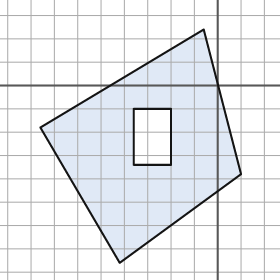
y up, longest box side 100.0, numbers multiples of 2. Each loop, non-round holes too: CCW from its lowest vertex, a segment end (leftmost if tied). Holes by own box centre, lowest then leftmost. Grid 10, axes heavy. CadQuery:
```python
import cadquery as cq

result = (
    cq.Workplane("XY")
    .moveTo(-42.0, -76.0)
    .lineTo(10.0, -38.0)
    .lineTo(-6.0, 24.0)
    .lineTo(-76.0, -18.0)
    .close()
    .moveTo(-36.0, -34.0)
    .lineTo(-20.0, -34.0)
    .lineTo(-20.0, -10.0)
    .lineTo(-36.0, -10.0)
    .close()
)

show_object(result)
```